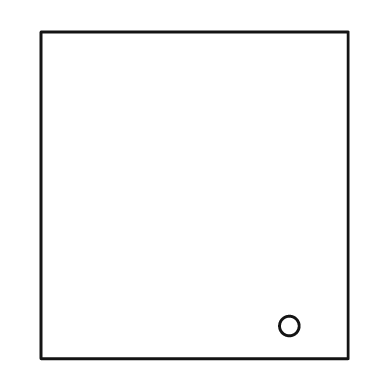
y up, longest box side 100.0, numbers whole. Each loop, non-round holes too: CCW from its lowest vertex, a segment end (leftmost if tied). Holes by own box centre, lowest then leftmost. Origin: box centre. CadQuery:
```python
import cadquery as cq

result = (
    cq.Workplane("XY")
    .moveTo(-47.0, -50.0)
    .lineTo(47.0, -50.0)
    .lineTo(47.0, 50.0)
    .lineTo(-47.0, 50.0)
    .close()
    .moveTo(29.0, -40.0)
    .circle(3.0)
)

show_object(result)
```